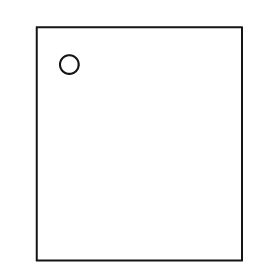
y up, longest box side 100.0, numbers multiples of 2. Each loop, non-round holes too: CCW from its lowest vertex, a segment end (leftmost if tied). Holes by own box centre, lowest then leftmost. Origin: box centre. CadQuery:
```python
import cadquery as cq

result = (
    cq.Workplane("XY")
    .moveTo(-44.0, -50.0)
    .lineTo(44.0, -50.0)
    .lineTo(44.0, 50.0)
    .lineTo(-44.0, 50.0)
    .close()
    .moveTo(-30.0, 34.0)
    .circle(4.0)
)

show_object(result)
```